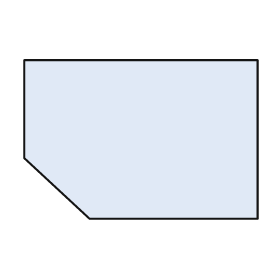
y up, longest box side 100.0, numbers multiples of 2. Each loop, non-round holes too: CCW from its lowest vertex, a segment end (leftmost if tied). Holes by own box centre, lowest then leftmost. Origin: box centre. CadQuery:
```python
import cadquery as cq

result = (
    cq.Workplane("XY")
    .moveTo(-22.0, -34.0)
    .lineTo(50.0, -34.0)
    .lineTo(50.0, 34.0)
    .lineTo(-50.0, 34.0)
    .lineTo(-50.0, -8.0)
    .close()
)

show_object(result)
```